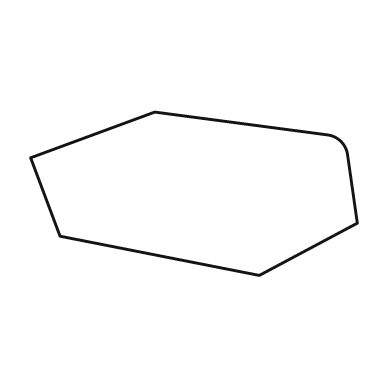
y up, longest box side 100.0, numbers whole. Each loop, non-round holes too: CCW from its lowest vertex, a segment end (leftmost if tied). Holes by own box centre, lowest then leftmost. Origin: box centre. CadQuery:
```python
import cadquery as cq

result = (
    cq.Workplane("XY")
    .moveTo(20.0, -25.0)
    .lineTo(50.0, -9.0)
    .lineTo(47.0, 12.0)
    .threePointArc((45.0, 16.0), (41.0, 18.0))
    .lineTo(-12.0, 25.0)
    .lineTo(-50.0, 11.0)
    .lineTo(-41.0, -13.0)
    .close()
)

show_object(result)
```